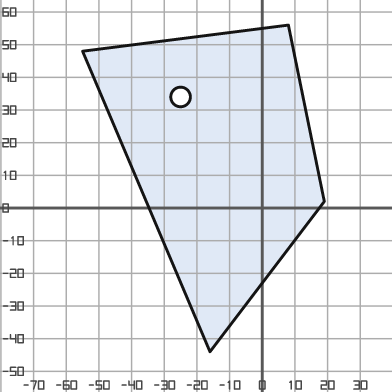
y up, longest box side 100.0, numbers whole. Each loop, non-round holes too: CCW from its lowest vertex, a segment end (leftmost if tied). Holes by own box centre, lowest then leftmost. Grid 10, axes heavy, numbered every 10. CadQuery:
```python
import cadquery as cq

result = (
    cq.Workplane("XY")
    .moveTo(-16.0, -44.0)
    .lineTo(19.0, 2.0)
    .lineTo(8.0, 56.0)
    .lineTo(-55.0, 48.0)
    .close()
    .moveTo(-25.0, 34.0)
    .circle(3.0)
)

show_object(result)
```